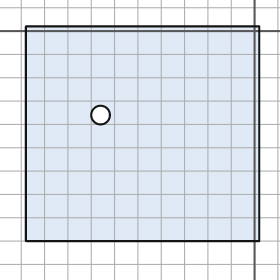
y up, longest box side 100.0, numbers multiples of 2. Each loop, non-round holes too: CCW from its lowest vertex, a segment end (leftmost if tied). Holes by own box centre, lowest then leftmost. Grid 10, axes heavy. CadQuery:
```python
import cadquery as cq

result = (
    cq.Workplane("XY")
    .moveTo(-98.0, -90.0)
    .lineTo(2.0, -90.0)
    .lineTo(2.0, 2.0)
    .lineTo(-98.0, 2.0)
    .close()
    .moveTo(-66.0, -36.0)
    .circle(4.0)
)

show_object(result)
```